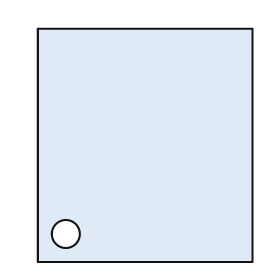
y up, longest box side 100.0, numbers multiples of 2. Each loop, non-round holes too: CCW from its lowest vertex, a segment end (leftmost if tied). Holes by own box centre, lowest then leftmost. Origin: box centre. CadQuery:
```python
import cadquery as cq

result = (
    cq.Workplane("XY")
    .moveTo(-46.0, -50.0)
    .lineTo(46.0, -50.0)
    .lineTo(46.0, 50.0)
    .lineTo(-46.0, 50.0)
    .close()
    .moveTo(-34.0, -38.0)
    .circle(6.0)
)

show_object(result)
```